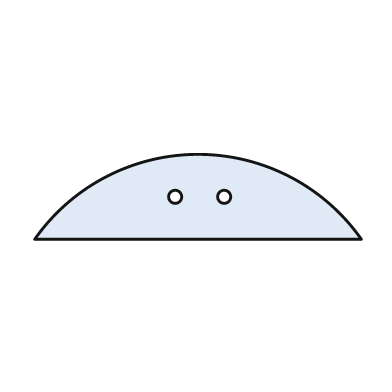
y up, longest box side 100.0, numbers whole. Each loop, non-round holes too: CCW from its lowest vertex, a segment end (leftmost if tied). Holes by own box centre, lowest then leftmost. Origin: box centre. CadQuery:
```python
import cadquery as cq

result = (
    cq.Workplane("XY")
    .moveTo(-50.0, -13.0)
    .lineTo(50.0, -13.0)
    .threePointArc((0.0, 13.0), (-50.0, -13.0))
    .close()
    .moveTo(-7.0, 0.0)
    .circle(2.0)
    .moveTo(8.0, 0.0)
    .circle(2.0)
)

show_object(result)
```